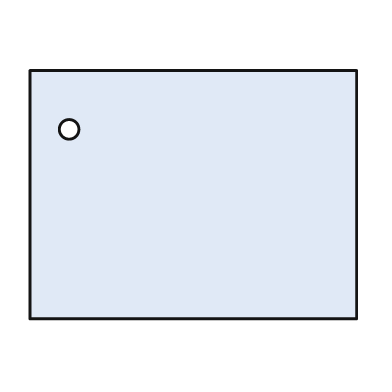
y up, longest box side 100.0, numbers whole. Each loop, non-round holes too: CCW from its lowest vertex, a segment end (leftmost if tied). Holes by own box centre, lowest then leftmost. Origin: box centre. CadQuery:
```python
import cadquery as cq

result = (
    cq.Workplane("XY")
    .moveTo(-50.0, -38.0)
    .lineTo(50.0, -38.0)
    .lineTo(50.0, 38.0)
    .lineTo(-50.0, 38.0)
    .close()
    .moveTo(-38.0, 20.0)
    .circle(3.0)
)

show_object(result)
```